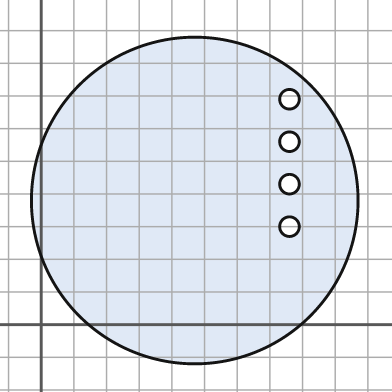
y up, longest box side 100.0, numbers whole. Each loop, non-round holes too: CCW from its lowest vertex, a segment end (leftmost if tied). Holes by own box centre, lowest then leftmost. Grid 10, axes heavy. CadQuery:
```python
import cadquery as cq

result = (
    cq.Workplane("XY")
    .moveTo(47.0, 38.0)
    .circle(50.0)
    .moveTo(76.0, 30.0)
    .circle(3.0)
    .moveTo(76.0, 43.0)
    .circle(3.0)
    .moveTo(76.0, 56.0)
    .circle(3.0)
    .moveTo(76.0, 69.0)
    .circle(3.0)
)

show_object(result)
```